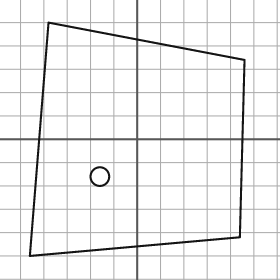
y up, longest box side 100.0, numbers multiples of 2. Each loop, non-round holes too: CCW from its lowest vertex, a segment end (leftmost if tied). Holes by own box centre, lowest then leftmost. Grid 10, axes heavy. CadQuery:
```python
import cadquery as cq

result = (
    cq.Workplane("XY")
    .moveTo(-46.0, -50.0)
    .lineTo(44.0, -42.0)
    .lineTo(46.0, 34.0)
    .lineTo(-38.0, 50.0)
    .close()
    .moveTo(-16.0, -16.0)
    .circle(4.0)
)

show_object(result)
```